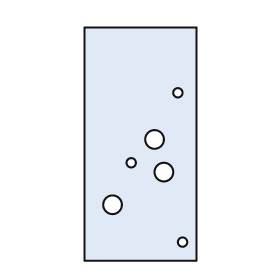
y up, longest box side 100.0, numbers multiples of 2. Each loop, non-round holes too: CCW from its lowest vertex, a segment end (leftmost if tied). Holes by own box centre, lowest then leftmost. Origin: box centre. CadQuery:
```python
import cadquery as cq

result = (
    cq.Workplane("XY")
    .moveTo(-24.0, -50.0)
    .lineTo(24.0, -50.0)
    .lineTo(24.0, 50.0)
    .lineTo(-24.0, 50.0)
    .close()
    .moveTo(18.0, -42.0)
    .circle(2.0)
    .moveTo(-12.0, -26.0)
    .circle(4.0)
    .moveTo(10.0, -12.0)
    .circle(4.0)
    .moveTo(-4.0, -8.0)
    .circle(2.0)
    .moveTo(6.0, 2.0)
    .circle(4.0)
    .moveTo(16.0, 22.0)
    .circle(2.0)
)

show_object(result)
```